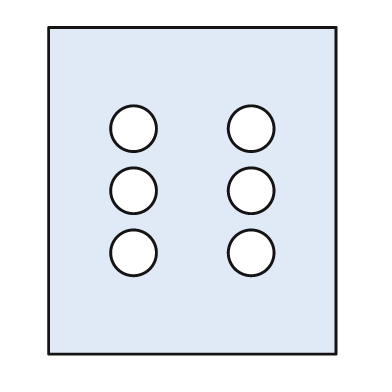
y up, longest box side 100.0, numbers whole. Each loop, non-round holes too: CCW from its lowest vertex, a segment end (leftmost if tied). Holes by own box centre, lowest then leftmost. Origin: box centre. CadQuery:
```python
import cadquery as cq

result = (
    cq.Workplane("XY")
    .moveTo(-44.0, -50.0)
    .lineTo(44.0, -50.0)
    .lineTo(44.0, 50.0)
    .lineTo(-44.0, 50.0)
    .close()
    .moveTo(-18.0, -19.0)
    .circle(7.0)
    .moveTo(18.0, -19.0)
    .circle(7.0)
    .moveTo(-18.0, 0.0)
    .circle(7.0)
    .moveTo(18.0, 0.0)
    .circle(7.0)
    .moveTo(-18.0, 19.0)
    .circle(7.0)
    .moveTo(18.0, 19.0)
    .circle(7.0)
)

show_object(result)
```